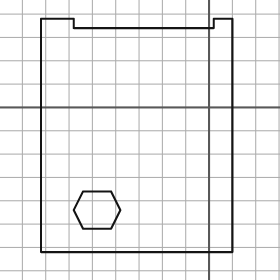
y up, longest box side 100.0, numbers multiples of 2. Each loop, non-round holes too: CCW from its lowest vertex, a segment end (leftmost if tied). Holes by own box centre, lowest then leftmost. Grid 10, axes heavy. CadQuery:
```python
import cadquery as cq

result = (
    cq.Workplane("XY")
    .moveTo(-72.0, -62.0)
    .lineTo(10.0, -62.0)
    .lineTo(10.0, 38.0)
    .lineTo(2.0, 38.0)
    .lineTo(2.0, 34.0)
    .lineTo(-58.0, 34.0)
    .lineTo(-58.0, 38.0)
    .lineTo(-72.0, 38.0)
    .close()
    .moveTo(-54.0, -52.0)
    .lineTo(-42.0, -52.0)
    .lineTo(-38.0, -44.0)
    .lineTo(-42.0, -36.0)
    .lineTo(-54.0, -36.0)
    .lineTo(-58.0, -44.0)
    .close()
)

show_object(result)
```